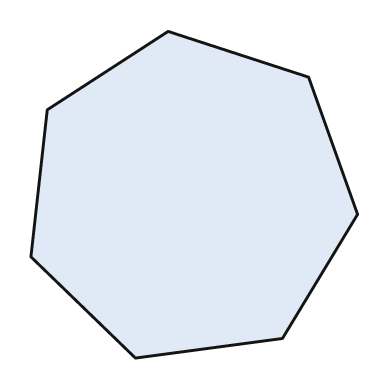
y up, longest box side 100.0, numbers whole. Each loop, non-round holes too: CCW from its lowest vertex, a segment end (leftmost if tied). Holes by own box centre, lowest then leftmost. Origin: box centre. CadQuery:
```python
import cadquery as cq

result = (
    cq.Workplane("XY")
    .moveTo(-18.0, -50.0)
    .lineTo(27.0, -44.0)
    .lineTo(50.0, -6.0)
    .lineTo(35.0, 36.0)
    .lineTo(-8.0, 50.0)
    .lineTo(-45.0, 26.0)
    .lineTo(-50.0, -19.0)
    .close()
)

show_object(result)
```